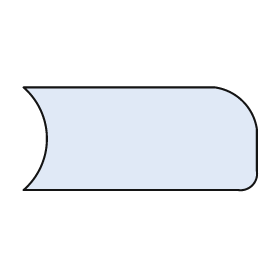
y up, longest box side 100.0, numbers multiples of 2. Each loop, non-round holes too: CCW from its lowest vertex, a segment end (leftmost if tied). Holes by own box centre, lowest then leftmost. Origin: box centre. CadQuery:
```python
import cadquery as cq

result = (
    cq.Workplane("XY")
    .moveTo(-50.0, -22.0)
    .lineTo(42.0, -22.0)
    .threePointArc((48.0, -20.0), (50.0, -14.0))
    .lineTo(50.0, 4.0)
    .threePointArc((44.0, 16.0), (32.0, 22.0))
    .lineTo(-50.0, 22.0)
    .threePointArc((-40.0, 0.0), (-50.0, -22.0))
    .close()
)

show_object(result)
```